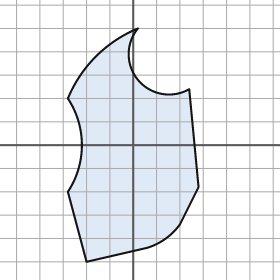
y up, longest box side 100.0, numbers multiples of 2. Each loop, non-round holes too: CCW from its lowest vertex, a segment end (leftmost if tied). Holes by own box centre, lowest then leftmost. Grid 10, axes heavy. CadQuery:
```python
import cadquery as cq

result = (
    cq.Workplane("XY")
    .moveTo(-20.0, -50.0)
    .lineTo(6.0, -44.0)
    .threePointArc((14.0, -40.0), (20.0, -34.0))
    .lineTo(28.0, -18.0)
    .lineTo(24.0, 24.0)
    .threePointArc((2.0, 28.0), (2.0, 50.0))
    .threePointArc((-16.0, 38.0), (-28.0, 20.0))
    .threePointArc((-22.0, 0.0), (-28.0, -20.0))
    .close()
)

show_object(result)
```